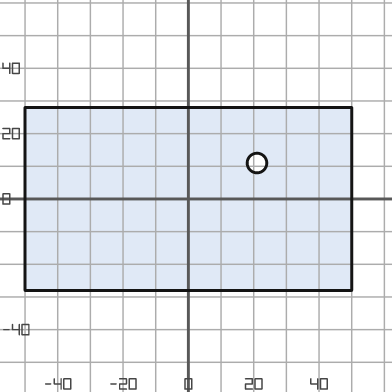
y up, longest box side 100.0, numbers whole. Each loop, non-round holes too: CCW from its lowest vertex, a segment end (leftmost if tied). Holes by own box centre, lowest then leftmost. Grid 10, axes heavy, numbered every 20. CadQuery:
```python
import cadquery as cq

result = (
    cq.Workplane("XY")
    .moveTo(-50.0, -28.0)
    .lineTo(50.0, -28.0)
    .lineTo(50.0, 28.0)
    .lineTo(-50.0, 28.0)
    .close()
    .moveTo(21.0, 11.0)
    .circle(3.0)
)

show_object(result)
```